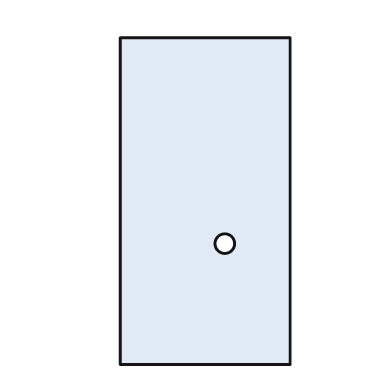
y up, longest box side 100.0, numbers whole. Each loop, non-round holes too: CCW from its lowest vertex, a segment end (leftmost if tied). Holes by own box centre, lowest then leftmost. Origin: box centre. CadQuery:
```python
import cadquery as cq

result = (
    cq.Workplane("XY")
    .moveTo(-26.0, -50.0)
    .lineTo(26.0, -50.0)
    .lineTo(26.0, 50.0)
    .lineTo(-26.0, 50.0)
    .close()
    .moveTo(6.0, -13.0)
    .circle(3.0)
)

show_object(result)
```